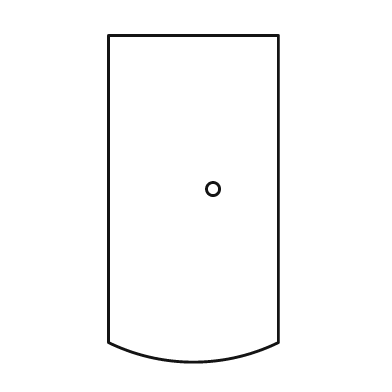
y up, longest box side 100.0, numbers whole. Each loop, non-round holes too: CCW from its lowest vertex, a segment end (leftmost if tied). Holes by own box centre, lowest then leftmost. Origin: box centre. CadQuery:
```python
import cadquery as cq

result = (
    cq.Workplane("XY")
    .moveTo(-26.0, -44.0)
    .threePointArc((0.0, -50.0), (26.0, -44.0))
    .lineTo(26.0, 50.0)
    .lineTo(-26.0, 50.0)
    .close()
    .moveTo(6.0, 3.0)
    .circle(2.0)
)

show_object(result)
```